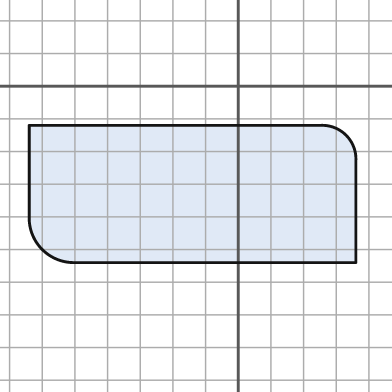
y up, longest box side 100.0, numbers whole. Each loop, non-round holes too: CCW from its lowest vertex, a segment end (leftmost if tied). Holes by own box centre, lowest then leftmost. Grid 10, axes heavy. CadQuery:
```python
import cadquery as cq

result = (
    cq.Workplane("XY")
    .moveTo(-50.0, -54.0)
    .lineTo(36.0, -54.0)
    .lineTo(36.0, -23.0)
    .threePointArc((33.0, -15.0), (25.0, -12.0))
    .lineTo(-64.0, -12.0)
    .lineTo(-64.0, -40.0)
    .threePointArc((-60.0, -50.0), (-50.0, -54.0))
    .close()
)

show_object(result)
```